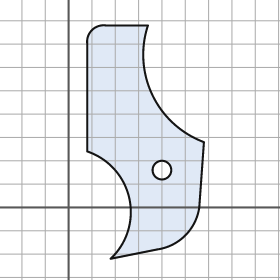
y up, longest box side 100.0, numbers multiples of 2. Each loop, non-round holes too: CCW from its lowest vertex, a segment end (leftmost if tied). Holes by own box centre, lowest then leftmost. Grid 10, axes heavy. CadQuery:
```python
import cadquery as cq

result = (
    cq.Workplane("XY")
    .moveTo(18.0, -22.0)
    .lineTo(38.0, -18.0)
    .threePointArc((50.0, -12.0), (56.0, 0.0))
    .lineTo(58.0, 28.0)
    .threePointArc((36.0, 48.0), (34.0, 78.0))
    .lineTo(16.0, 78.0)
    .threePointArc((10.0, 76.0), (8.0, 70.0))
    .lineTo(8.0, 24.0)
    .threePointArc((26.0, 4.0), (18.0, -22.0))
    .close()
    .moveTo(40.0, 16.0)
    .circle(4.0)
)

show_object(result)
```